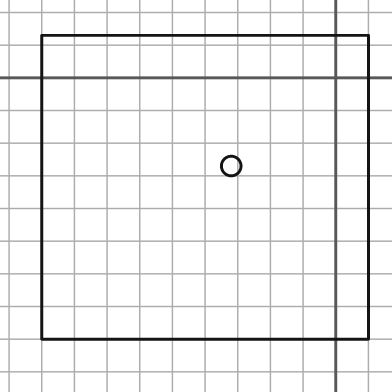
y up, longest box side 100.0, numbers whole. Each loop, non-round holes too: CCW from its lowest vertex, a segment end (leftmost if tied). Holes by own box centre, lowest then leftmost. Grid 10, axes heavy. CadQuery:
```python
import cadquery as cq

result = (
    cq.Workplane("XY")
    .moveTo(-90.0, -80.0)
    .lineTo(10.0, -80.0)
    .lineTo(10.0, 13.0)
    .lineTo(-90.0, 13.0)
    .close()
    .moveTo(-32.0, -27.0)
    .circle(3.0)
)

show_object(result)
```